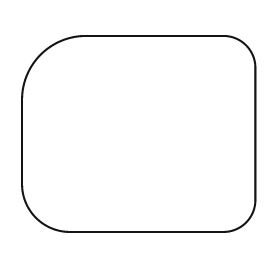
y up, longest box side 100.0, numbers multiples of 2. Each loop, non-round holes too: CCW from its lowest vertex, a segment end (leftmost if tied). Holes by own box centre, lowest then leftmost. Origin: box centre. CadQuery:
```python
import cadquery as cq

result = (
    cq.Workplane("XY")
    .moveTo(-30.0, -42.0)
    .lineTo(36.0, -42.0)
    .threePointArc((46.0, -38.0), (50.0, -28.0))
    .lineTo(50.0, 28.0)
    .threePointArc((46.0, 38.0), (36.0, 42.0))
    .lineTo(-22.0, 42.0)
    .threePointArc((-42.0, 34.0), (-50.0, 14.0))
    .lineTo(-50.0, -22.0)
    .threePointArc((-44.0, -36.0), (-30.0, -42.0))
    .close()
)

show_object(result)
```